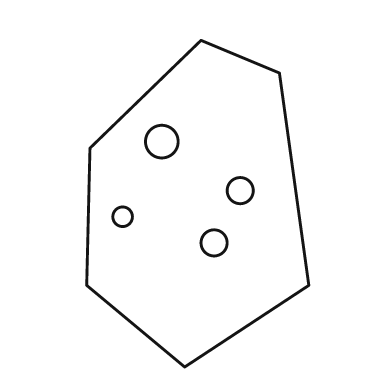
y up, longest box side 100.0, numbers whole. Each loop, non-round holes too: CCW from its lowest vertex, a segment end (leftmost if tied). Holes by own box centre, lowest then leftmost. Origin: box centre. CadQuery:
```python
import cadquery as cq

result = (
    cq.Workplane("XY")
    .moveTo(-4.0, -50.0)
    .lineTo(34.0, -25.0)
    .lineTo(25.0, 40.0)
    .lineTo(1.0, 50.0)
    .lineTo(-33.0, 17.0)
    .lineTo(-34.0, -25.0)
    .close()
    .moveTo(5.0, -12.0)
    .circle(4.0)
    .moveTo(-23.0, -4.0)
    .circle(3.0)
    .moveTo(13.0, 4.0)
    .circle(4.0)
    .moveTo(-11.0, 19.0)
    .circle(5.0)
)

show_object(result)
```